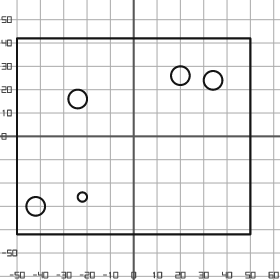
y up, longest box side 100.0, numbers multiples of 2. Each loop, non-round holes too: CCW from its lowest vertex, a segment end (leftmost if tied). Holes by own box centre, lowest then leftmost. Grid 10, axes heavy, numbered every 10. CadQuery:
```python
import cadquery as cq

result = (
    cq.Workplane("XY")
    .moveTo(-50.0, -42.0)
    .lineTo(50.0, -42.0)
    .lineTo(50.0, 42.0)
    .lineTo(-50.0, 42.0)
    .close()
    .moveTo(-42.0, -30.0)
    .circle(4.0)
    .moveTo(-22.0, -26.0)
    .circle(2.0)
    .moveTo(-24.0, 16.0)
    .circle(4.0)
    .moveTo(34.0, 24.0)
    .circle(4.0)
    .moveTo(20.0, 26.0)
    .circle(4.0)
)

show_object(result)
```